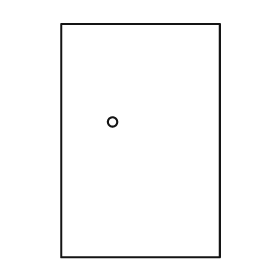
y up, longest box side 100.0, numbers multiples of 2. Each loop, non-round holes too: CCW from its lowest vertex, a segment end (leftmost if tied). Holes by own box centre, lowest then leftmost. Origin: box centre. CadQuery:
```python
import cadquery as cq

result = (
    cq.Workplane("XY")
    .moveTo(-34.0, -50.0)
    .lineTo(34.0, -50.0)
    .lineTo(34.0, 50.0)
    .lineTo(-34.0, 50.0)
    .close()
    .moveTo(-12.0, 8.0)
    .circle(2.0)
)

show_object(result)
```